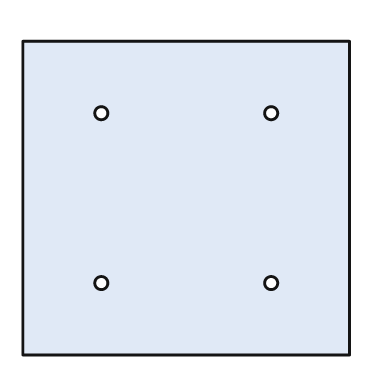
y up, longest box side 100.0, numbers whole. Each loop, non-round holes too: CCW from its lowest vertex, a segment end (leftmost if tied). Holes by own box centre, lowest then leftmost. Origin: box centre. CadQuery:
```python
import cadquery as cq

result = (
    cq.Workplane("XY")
    .moveTo(-50.0, -48.0)
    .lineTo(50.0, -48.0)
    .lineTo(50.0, 48.0)
    .lineTo(-50.0, 48.0)
    .close()
    .moveTo(-26.0, -26.0)
    .circle(2.0)
    .moveTo(26.0, -26.0)
    .circle(2.0)
    .moveTo(-26.0, 26.0)
    .circle(2.0)
    .moveTo(26.0, 26.0)
    .circle(2.0)
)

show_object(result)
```